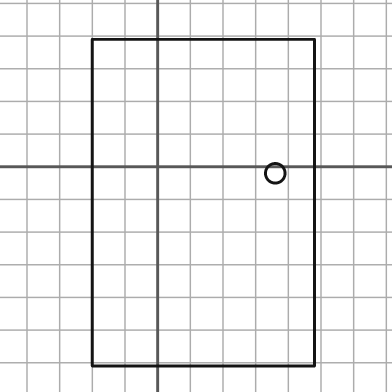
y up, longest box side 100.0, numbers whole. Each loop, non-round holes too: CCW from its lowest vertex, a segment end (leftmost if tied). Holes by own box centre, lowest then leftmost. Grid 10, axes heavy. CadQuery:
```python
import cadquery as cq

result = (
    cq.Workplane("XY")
    .moveTo(-20.0, -61.0)
    .lineTo(48.0, -61.0)
    .lineTo(48.0, 39.0)
    .lineTo(-20.0, 39.0)
    .close()
    .moveTo(36.0, -2.0)
    .circle(3.0)
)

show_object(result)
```